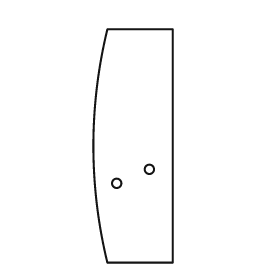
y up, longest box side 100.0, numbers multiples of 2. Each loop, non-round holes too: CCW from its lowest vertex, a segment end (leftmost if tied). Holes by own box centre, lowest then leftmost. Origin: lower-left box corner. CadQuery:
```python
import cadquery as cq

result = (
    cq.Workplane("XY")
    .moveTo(6.0, 0.0)
    .lineTo(34.0, 0.0)
    .lineTo(34.0, 100.0)
    .lineTo(6.0, 100.0)
    .threePointArc((0.0, 50.0), (6.0, 0.0))
    .close()
    .moveTo(10.0, 34.0)
    .circle(2.0)
    .moveTo(24.0, 40.0)
    .circle(2.0)
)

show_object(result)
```